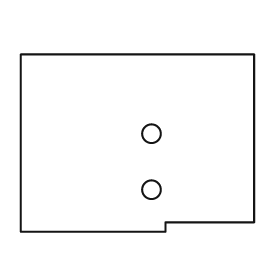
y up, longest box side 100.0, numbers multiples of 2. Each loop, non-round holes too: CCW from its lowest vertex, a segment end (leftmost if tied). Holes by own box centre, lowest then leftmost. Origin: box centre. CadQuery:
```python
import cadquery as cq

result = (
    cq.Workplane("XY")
    .moveTo(-50.0, -38.0)
    .lineTo(12.0, -38.0)
    .lineTo(12.0, -34.0)
    .lineTo(50.0, -34.0)
    .lineTo(50.0, 38.0)
    .lineTo(-50.0, 38.0)
    .close()
    .moveTo(6.0, -20.0)
    .circle(4.0)
    .moveTo(6.0, 4.0)
    .circle(4.0)
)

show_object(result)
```